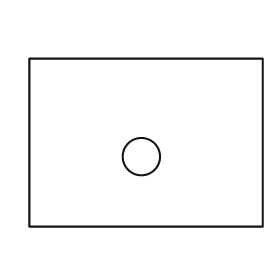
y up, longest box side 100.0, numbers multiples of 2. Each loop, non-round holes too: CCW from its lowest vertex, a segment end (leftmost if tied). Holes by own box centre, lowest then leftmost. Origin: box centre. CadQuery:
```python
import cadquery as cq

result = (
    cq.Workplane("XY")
    .moveTo(-50.0, -36.0)
    .lineTo(50.0, -36.0)
    .lineTo(50.0, 36.0)
    .lineTo(-50.0, 36.0)
    .close()
    .moveTo(-2.0, -6.0)
    .circle(8.0)
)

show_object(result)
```